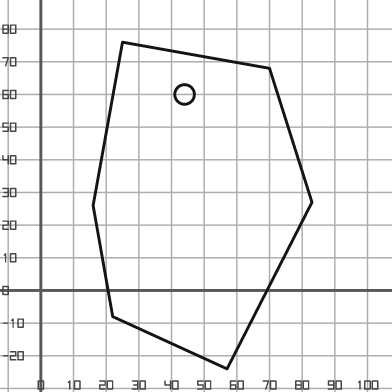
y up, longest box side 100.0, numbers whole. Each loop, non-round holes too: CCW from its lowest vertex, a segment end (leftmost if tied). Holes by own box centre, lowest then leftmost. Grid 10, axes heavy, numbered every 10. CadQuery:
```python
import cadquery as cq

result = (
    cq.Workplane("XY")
    .moveTo(57.0, -24.0)
    .lineTo(83.0, 27.0)
    .lineTo(70.0, 68.0)
    .lineTo(25.0, 76.0)
    .lineTo(16.0, 26.0)
    .lineTo(22.0, -8.0)
    .close()
    .moveTo(44.0, 60.0)
    .circle(3.0)
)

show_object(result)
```